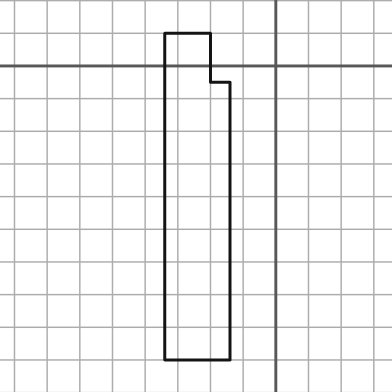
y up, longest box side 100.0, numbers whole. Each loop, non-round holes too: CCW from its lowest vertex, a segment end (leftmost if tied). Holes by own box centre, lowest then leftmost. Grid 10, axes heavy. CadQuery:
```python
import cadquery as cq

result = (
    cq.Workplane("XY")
    .moveTo(-34.0, -90.0)
    .lineTo(-14.0, -90.0)
    .lineTo(-14.0, -5.0)
    .lineTo(-20.0, -5.0)
    .lineTo(-20.0, 10.0)
    .lineTo(-34.0, 10.0)
    .close()
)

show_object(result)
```